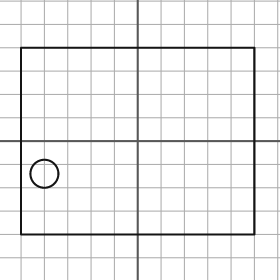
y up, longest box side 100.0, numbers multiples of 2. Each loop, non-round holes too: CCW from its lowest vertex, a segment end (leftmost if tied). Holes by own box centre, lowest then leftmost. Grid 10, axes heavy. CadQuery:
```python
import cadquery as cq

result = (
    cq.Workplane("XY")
    .moveTo(-50.0, -40.0)
    .lineTo(50.0, -40.0)
    .lineTo(50.0, 40.0)
    .lineTo(-50.0, 40.0)
    .close()
    .moveTo(-40.0, -14.0)
    .circle(6.0)
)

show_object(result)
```